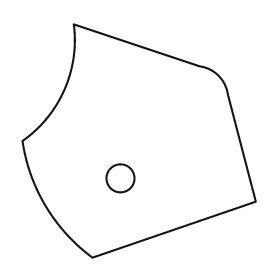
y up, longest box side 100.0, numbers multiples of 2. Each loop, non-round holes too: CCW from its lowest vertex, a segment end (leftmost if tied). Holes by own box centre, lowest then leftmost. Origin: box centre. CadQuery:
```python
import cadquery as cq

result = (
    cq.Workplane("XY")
    .moveTo(-20.0, -50.0)
    .lineTo(50.0, -26.0)
    .lineTo(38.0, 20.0)
    .threePointArc((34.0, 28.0), (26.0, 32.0))
    .lineTo(-28.0, 50.0)
    .threePointArc((-32.0, 22.0), (-50.0, 0.0))
    .threePointArc((-40.0, -28.0), (-20.0, -50.0))
    .close()
    .moveTo(-8.0, -16.0)
    .circle(6.0)
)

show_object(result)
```